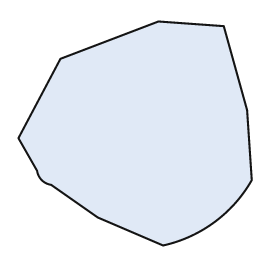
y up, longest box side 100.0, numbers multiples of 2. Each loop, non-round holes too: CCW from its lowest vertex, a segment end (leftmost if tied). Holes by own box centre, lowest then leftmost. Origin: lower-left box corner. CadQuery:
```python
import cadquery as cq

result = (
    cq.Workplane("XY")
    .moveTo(62.0, 0.0)
    .threePointArc((84.0, 10.0), (100.0, 28.0))
    .lineTo(98.0, 58.0)
    .lineTo(88.0, 94.0)
    .lineTo(60.0, 96.0)
    .lineTo(18.0, 80.0)
    .lineTo(0.0, 46.0)
    .lineTo(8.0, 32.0)
    .threePointArc((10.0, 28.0), (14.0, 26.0))
    .lineTo(34.0, 12.0)
    .close()
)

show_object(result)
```